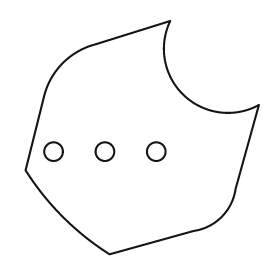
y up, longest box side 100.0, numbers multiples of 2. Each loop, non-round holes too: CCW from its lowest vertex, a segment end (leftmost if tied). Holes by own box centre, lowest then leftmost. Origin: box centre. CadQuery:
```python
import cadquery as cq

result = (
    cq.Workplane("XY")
    .moveTo(-14.0, -50.0)
    .lineTo(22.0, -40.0)
    .threePointArc((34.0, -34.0), (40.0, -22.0))
    .lineTo(50.0, 14.0)
    .threePointArc((18.0, 18.0), (12.0, 50.0))
    .lineTo(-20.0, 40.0)
    .threePointArc((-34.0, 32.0), (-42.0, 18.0))
    .lineTo(-50.0, -14.0)
    .threePointArc((-34.0, -34.0), (-14.0, -50.0))
    .close()
    .moveTo(-38.0, -6.0)
    .circle(4.0)
    .moveTo(-16.0, -6.0)
    .circle(4.0)
    .moveTo(6.0, -6.0)
    .circle(4.0)
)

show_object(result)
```